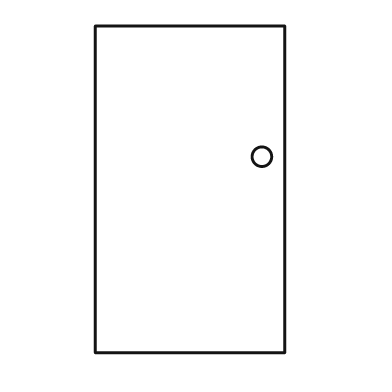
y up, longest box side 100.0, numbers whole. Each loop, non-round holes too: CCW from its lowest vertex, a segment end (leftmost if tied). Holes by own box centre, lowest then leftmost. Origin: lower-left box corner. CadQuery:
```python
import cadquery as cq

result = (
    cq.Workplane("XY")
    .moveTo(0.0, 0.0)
    .lineTo(58.0, 0.0)
    .lineTo(58.0, 100.0)
    .lineTo(0.0, 100.0)
    .close()
    .moveTo(51.0, 60.0)
    .circle(3.0)
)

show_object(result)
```